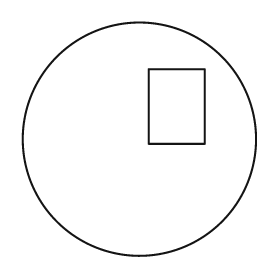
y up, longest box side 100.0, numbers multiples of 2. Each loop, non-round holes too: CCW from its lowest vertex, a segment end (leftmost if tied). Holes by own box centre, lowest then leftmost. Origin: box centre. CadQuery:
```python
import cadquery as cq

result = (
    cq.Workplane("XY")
    .moveTo(0.0, 0.0)
    .circle(50.0)
    .moveTo(4.0, -2.0)
    .lineTo(28.0, -2.0)
    .lineTo(28.0, 30.0)
    .lineTo(4.0, 30.0)
    .close()
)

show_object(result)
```